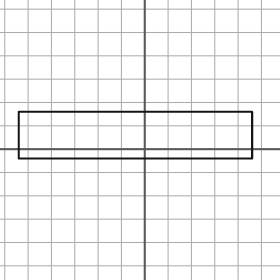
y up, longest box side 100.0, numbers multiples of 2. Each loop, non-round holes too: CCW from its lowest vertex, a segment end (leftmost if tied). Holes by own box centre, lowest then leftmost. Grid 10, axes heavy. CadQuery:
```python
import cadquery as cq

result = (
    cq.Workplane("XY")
    .moveTo(-54.0, -4.0)
    .lineTo(46.0, -4.0)
    .lineTo(46.0, 16.0)
    .lineTo(-54.0, 16.0)
    .close()
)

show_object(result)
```